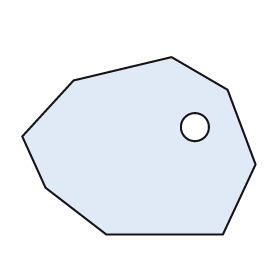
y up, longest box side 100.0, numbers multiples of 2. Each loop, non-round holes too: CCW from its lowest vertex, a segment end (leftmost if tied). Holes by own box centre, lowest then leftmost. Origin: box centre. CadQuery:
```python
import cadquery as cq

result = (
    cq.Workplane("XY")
    .moveTo(-14.0, -38.0)
    .lineTo(36.0, -38.0)
    .lineTo(50.0, -8.0)
    .lineTo(38.0, 24.0)
    .lineTo(14.0, 38.0)
    .lineTo(-28.0, 28.0)
    .lineTo(-50.0, 4.0)
    .lineTo(-40.0, -18.0)
    .close()
    .moveTo(24.0, 8.0)
    .circle(6.0)
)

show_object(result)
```